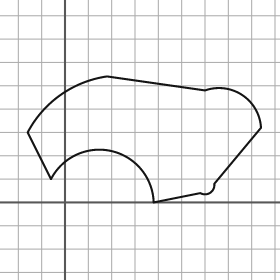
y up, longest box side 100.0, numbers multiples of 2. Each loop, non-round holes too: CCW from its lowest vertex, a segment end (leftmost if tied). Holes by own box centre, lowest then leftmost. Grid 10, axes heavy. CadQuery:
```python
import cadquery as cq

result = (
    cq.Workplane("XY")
    .moveTo(38.0, 0.0)
    .lineTo(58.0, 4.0)
    .threePointArc((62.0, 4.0), (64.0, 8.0))
    .lineTo(84.0, 32.0)
    .threePointArc((76.0, 46.0), (60.0, 48.0))
    .lineTo(18.0, 54.0)
    .threePointArc((-2.0, 46.0), (-16.0, 30.0))
    .lineTo(-6.0, 10.0)
    .threePointArc((20.0, 22.0), (38.0, 0.0))
    .close()
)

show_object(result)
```